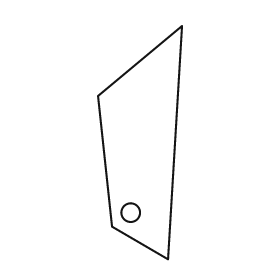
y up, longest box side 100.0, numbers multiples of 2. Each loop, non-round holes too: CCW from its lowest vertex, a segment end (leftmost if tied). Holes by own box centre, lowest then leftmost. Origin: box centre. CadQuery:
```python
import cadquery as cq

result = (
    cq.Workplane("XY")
    .moveTo(12.0, -50.0)
    .lineTo(18.0, 50.0)
    .lineTo(-18.0, 20.0)
    .lineTo(-12.0, -36.0)
    .close()
    .moveTo(-4.0, -30.0)
    .circle(4.0)
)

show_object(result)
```